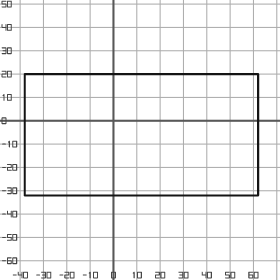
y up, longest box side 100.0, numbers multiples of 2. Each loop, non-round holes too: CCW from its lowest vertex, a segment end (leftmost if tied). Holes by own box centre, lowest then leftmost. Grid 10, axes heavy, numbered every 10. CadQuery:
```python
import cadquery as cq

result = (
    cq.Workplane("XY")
    .moveTo(-38.0, -32.0)
    .lineTo(62.0, -32.0)
    .lineTo(62.0, 20.0)
    .lineTo(-38.0, 20.0)
    .close()
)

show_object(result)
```